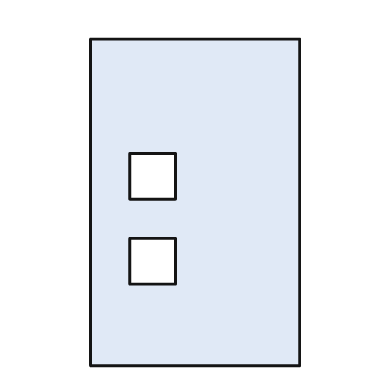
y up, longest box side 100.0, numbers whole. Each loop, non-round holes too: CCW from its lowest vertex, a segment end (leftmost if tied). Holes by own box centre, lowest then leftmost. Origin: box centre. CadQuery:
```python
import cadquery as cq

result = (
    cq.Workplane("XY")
    .moveTo(-32.0, -50.0)
    .lineTo(32.0, -50.0)
    .lineTo(32.0, 50.0)
    .lineTo(-32.0, 50.0)
    .close()
    .moveTo(-20.0, -25.0)
    .lineTo(-6.0, -25.0)
    .lineTo(-6.0, -11.0)
    .lineTo(-20.0, -11.0)
    .close()
    .moveTo(-20.0, 1.0)
    .lineTo(-6.0, 1.0)
    .lineTo(-6.0, 15.0)
    .lineTo(-20.0, 15.0)
    .close()
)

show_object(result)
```